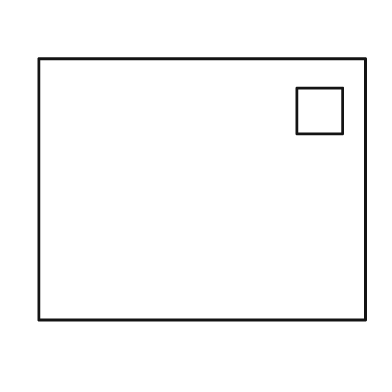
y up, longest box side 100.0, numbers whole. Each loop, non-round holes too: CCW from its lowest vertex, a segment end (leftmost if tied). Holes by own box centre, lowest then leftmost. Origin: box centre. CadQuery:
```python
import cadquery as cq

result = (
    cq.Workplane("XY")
    .moveTo(-50.0, -40.0)
    .lineTo(50.0, -40.0)
    .lineTo(50.0, 40.0)
    .lineTo(-50.0, 40.0)
    .close()
    .moveTo(29.0, 17.0)
    .lineTo(43.0, 17.0)
    .lineTo(43.0, 31.0)
    .lineTo(29.0, 31.0)
    .close()
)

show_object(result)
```